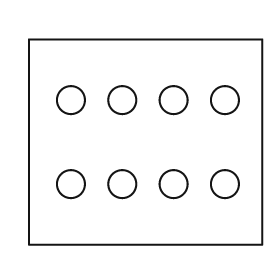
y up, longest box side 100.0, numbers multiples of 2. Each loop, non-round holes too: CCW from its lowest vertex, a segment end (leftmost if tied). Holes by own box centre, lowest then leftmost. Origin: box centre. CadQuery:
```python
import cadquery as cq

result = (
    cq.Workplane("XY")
    .moveTo(-50.0, -44.0)
    .lineTo(50.0, -44.0)
    .lineTo(50.0, 44.0)
    .lineTo(-50.0, 44.0)
    .close()
    .moveTo(-32.0, -18.0)
    .circle(6.0)
    .moveTo(-10.0, -18.0)
    .circle(6.0)
    .moveTo(12.0, -18.0)
    .circle(6.0)
    .moveTo(34.0, -18.0)
    .circle(6.0)
    .moveTo(-32.0, 18.0)
    .circle(6.0)
    .moveTo(-10.0, 18.0)
    .circle(6.0)
    .moveTo(12.0, 18.0)
    .circle(6.0)
    .moveTo(34.0, 18.0)
    .circle(6.0)
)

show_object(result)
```